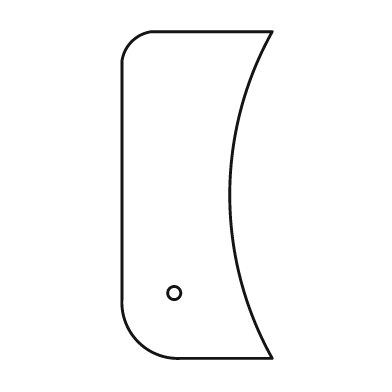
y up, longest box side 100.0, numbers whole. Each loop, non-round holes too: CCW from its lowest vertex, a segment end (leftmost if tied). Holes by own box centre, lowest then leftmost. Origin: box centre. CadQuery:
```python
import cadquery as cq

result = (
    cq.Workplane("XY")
    .moveTo(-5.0, -50.0)
    .lineTo(23.0, -50.0)
    .threePointArc((10.0, 0.0), (23.0, 50.0))
    .lineTo(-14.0, 50.0)
    .threePointArc((-20.0, 47.0), (-23.0, 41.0))
    .lineTo(-23.0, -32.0)
    .threePointArc((-18.0, -45.0), (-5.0, -50.0))
    .close()
    .moveTo(-7.0, -30.0)
    .circle(2.0)
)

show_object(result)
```